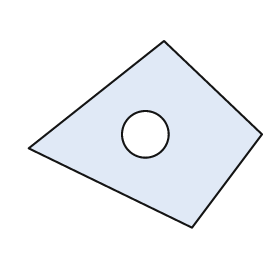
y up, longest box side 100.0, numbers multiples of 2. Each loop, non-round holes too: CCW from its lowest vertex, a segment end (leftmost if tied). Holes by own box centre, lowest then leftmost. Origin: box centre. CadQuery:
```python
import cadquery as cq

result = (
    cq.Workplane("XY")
    .moveTo(20.0, -40.0)
    .lineTo(50.0, 0.0)
    .lineTo(8.0, 40.0)
    .lineTo(-50.0, -6.0)
    .close()
    .moveTo(0.0, 0.0)
    .circle(10.0)
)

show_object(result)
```